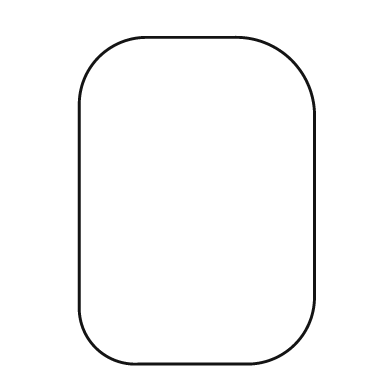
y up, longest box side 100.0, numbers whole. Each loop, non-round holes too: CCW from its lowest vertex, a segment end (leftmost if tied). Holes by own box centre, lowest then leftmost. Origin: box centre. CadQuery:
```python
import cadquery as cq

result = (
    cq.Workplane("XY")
    .moveTo(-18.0, -50.0)
    .lineTo(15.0, -50.0)
    .threePointArc((30.0, -44.0), (36.0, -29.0))
    .lineTo(36.0, 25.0)
    .threePointArc((29.0, 43.0), (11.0, 50.0))
    .lineTo(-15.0, 50.0)
    .threePointArc((-30.0, 44.0), (-36.0, 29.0))
    .lineTo(-36.0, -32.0)
    .threePointArc((-31.0, -45.0), (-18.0, -50.0))
    .close()
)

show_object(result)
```